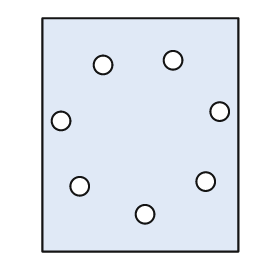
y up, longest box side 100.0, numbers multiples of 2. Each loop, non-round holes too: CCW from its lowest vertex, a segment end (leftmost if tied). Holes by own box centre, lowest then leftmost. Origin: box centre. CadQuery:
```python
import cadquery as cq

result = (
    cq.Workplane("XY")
    .moveTo(-42.0, -50.0)
    .lineTo(42.0, -50.0)
    .lineTo(42.0, 50.0)
    .lineTo(-42.0, 50.0)
    .close()
    .moveTo(2.0, -34.0)
    .circle(4.0)
    .moveTo(-26.0, -22.0)
    .circle(4.0)
    .moveTo(28.0, -20.0)
    .circle(4.0)
    .moveTo(-34.0, 6.0)
    .circle(4.0)
    .moveTo(34.0, 10.0)
    .circle(4.0)
    .moveTo(-16.0, 30.0)
    .circle(4.0)
    .moveTo(14.0, 32.0)
    .circle(4.0)
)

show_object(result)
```